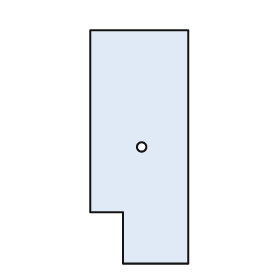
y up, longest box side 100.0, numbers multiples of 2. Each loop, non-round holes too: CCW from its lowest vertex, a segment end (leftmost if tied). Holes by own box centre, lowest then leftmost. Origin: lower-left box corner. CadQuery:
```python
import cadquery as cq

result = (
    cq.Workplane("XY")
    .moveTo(14.0, 0.0)
    .lineTo(42.0, 0.0)
    .lineTo(42.0, 100.0)
    .lineTo(0.0, 100.0)
    .lineTo(0.0, 22.0)
    .lineTo(14.0, 22.0)
    .close()
    .moveTo(22.0, 50.0)
    .circle(2.0)
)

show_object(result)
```